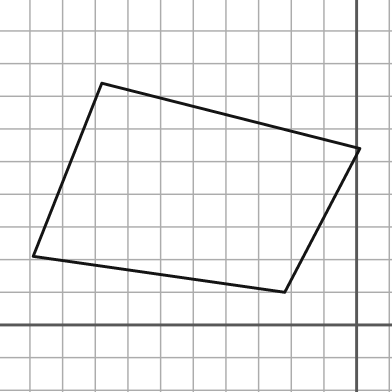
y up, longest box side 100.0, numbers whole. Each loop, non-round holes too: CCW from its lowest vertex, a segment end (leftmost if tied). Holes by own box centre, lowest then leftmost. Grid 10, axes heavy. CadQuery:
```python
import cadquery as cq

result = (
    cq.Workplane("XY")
    .moveTo(-22.0, 10.0)
    .lineTo(1.0, 54.0)
    .lineTo(-78.0, 74.0)
    .lineTo(-99.0, 21.0)
    .close()
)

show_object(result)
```